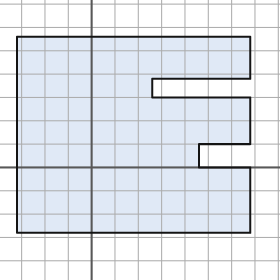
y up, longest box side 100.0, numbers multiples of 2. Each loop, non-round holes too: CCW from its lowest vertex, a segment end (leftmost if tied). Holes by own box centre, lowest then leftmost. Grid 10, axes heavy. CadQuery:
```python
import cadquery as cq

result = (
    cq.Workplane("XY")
    .moveTo(-32.0, -28.0)
    .lineTo(68.0, -28.0)
    .lineTo(68.0, 0.0)
    .lineTo(46.0, 0.0)
    .lineTo(46.0, 10.0)
    .lineTo(68.0, 10.0)
    .lineTo(68.0, 30.0)
    .lineTo(26.0, 30.0)
    .lineTo(26.0, 38.0)
    .lineTo(68.0, 38.0)
    .lineTo(68.0, 56.0)
    .lineTo(-32.0, 56.0)
    .close()
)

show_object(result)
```